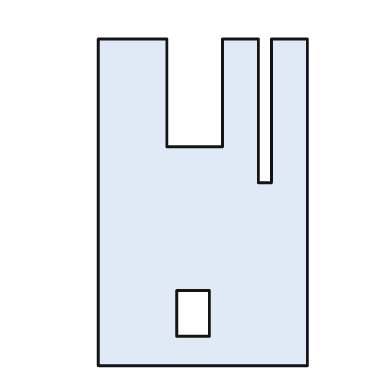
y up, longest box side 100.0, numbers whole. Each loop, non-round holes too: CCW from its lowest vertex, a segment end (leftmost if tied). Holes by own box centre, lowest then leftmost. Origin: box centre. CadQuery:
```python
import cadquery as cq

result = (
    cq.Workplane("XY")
    .moveTo(-32.0, -50.0)
    .lineTo(32.0, -50.0)
    .lineTo(32.0, 50.0)
    .lineTo(21.0, 50.0)
    .lineTo(21.0, 6.0)
    .lineTo(17.0, 6.0)
    .lineTo(17.0, 50.0)
    .lineTo(6.0, 50.0)
    .lineTo(6.0, 17.0)
    .lineTo(-11.0, 17.0)
    .lineTo(-11.0, 50.0)
    .lineTo(-32.0, 50.0)
    .close()
    .moveTo(-8.0, -41.0)
    .lineTo(2.0, -41.0)
    .lineTo(2.0, -27.0)
    .lineTo(-8.0, -27.0)
    .close()
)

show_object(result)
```